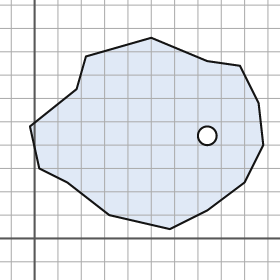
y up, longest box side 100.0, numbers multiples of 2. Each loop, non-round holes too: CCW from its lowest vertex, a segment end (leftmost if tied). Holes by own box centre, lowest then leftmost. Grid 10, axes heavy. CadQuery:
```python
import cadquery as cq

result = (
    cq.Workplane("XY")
    .moveTo(58.0, 4.0)
    .lineTo(74.0, 12.0)
    .lineTo(90.0, 24.0)
    .lineTo(98.0, 40.0)
    .lineTo(96.0, 58.0)
    .lineTo(88.0, 74.0)
    .lineTo(74.0, 76.0)
    .lineTo(50.0, 86.0)
    .lineTo(22.0, 78.0)
    .lineTo(18.0, 64.0)
    .lineTo(-2.0, 48.0)
    .lineTo(2.0, 30.0)
    .lineTo(14.0, 24.0)
    .lineTo(32.0, 10.0)
    .close()
    .moveTo(74.0, 44.0)
    .circle(4.0)
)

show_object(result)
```